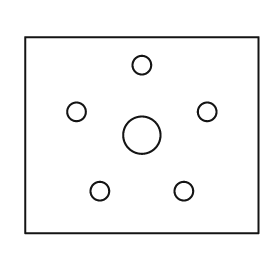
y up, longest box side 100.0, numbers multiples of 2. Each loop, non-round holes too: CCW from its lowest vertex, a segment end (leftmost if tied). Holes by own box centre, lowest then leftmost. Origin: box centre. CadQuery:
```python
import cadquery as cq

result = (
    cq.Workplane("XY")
    .moveTo(-50.0, -42.0)
    .lineTo(50.0, -42.0)
    .lineTo(50.0, 42.0)
    .lineTo(-50.0, 42.0)
    .close()
    .moveTo(-18.0, -24.0)
    .circle(4.0)
    .moveTo(18.0, -24.0)
    .circle(4.0)
    .moveTo(0.0, 0.0)
    .circle(8.0)
    .moveTo(-28.0, 10.0)
    .circle(4.0)
    .moveTo(28.0, 10.0)
    .circle(4.0)
    .moveTo(0.0, 30.0)
    .circle(4.0)
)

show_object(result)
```